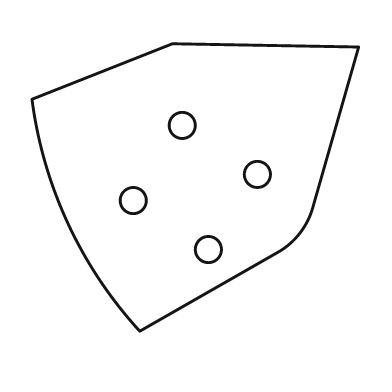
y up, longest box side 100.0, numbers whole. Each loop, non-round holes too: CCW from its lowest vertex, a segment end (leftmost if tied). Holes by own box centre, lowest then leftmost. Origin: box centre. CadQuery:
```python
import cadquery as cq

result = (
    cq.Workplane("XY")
    .moveTo(-17.0, -44.0)
    .lineTo(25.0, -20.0)
    .threePointArc((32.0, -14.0), (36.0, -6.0))
    .lineTo(50.0, 43.0)
    .lineTo(-7.0, 44.0)
    .lineTo(-50.0, 27.0)
    .threePointArc((-39.0, -11.0), (-17.0, -44.0))
    .close()
    .moveTo(4.0, -19.0)
    .circle(4.0)
    .moveTo(-19.0, -4.0)
    .circle(4.0)
    .moveTo(19.0, 4.0)
    .circle(4.0)
    .moveTo(-4.0, 19.0)
    .circle(4.0)
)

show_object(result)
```